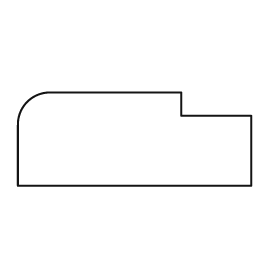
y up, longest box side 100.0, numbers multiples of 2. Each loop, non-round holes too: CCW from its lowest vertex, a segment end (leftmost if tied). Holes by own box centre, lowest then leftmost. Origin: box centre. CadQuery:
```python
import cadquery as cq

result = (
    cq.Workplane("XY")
    .moveTo(-50.0, -20.0)
    .lineTo(50.0, -20.0)
    .lineTo(50.0, 10.0)
    .lineTo(20.0, 10.0)
    .lineTo(20.0, 20.0)
    .lineTo(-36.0, 20.0)
    .threePointArc((-46.0, 16.0), (-50.0, 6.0))
    .close()
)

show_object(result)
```